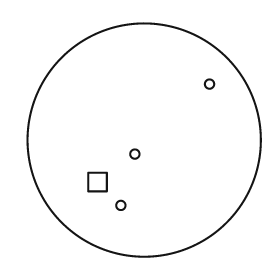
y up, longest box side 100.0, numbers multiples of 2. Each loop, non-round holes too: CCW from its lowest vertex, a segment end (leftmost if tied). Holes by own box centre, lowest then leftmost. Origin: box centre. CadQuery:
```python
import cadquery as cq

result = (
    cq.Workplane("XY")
    .moveTo(0.0, 0.0)
    .circle(50.0)
    .moveTo(-10.0, -28.0)
    .circle(2.0)
    .moveTo(-24.0, -22.0)
    .lineTo(-16.0, -22.0)
    .lineTo(-16.0, -14.0)
    .lineTo(-24.0, -14.0)
    .close()
    .moveTo(-4.0, -6.0)
    .circle(2.0)
    .moveTo(28.0, 24.0)
    .circle(2.0)
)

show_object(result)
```